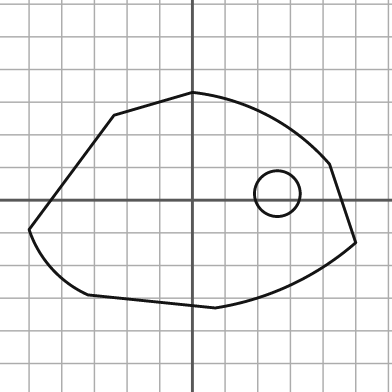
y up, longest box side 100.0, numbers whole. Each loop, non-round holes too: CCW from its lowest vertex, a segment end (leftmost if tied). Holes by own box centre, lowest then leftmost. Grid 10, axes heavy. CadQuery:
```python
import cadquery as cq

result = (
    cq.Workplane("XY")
    .moveTo(7.0, -33.0)
    .threePointArc((30.0, -26.0), (50.0, -13.0))
    .lineTo(42.0, 11.0)
    .threePointArc((23.0, 26.0), (0.0, 33.0))
    .lineTo(-24.0, 26.0)
    .lineTo(-50.0, -9.0)
    .threePointArc((-43.0, -21.0), (-32.0, -29.0))
    .close()
    .moveTo(26.0, 2.0)
    .circle(7.0)
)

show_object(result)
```